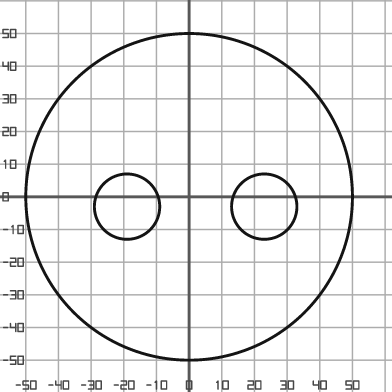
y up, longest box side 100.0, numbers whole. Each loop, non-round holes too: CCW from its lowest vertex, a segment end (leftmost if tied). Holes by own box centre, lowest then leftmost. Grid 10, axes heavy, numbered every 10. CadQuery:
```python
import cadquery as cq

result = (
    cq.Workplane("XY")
    .moveTo(0.0, 0.0)
    .circle(50.0)
    .moveTo(-19.0, -3.0)
    .circle(10.0)
    .moveTo(23.0, -3.0)
    .circle(10.0)
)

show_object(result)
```